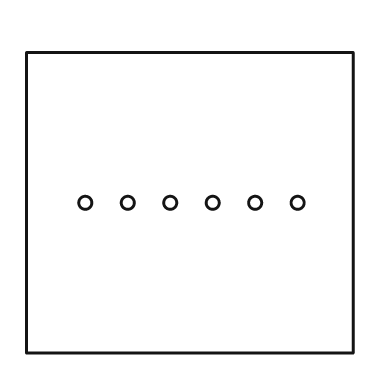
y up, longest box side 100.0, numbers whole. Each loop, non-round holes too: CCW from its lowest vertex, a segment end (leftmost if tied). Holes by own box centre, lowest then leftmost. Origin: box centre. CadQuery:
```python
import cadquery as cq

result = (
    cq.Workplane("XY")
    .moveTo(-50.0, -46.0)
    .lineTo(50.0, -46.0)
    .lineTo(50.0, 46.0)
    .lineTo(-50.0, 46.0)
    .close()
    .moveTo(-32.0, 0.0)
    .circle(2.0)
    .moveTo(-19.0, 0.0)
    .circle(2.0)
    .moveTo(-6.0, 0.0)
    .circle(2.0)
    .moveTo(7.0, 0.0)
    .circle(2.0)
    .moveTo(20.0, 0.0)
    .circle(2.0)
    .moveTo(33.0, 0.0)
    .circle(2.0)
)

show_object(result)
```